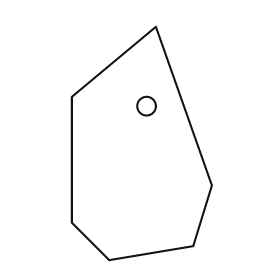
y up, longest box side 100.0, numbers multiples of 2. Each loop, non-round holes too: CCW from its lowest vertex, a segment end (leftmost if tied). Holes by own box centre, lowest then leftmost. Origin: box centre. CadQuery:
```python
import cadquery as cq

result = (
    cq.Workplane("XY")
    .moveTo(-14.0, -50.0)
    .lineTo(22.0, -44.0)
    .lineTo(30.0, -18.0)
    .lineTo(6.0, 50.0)
    .lineTo(-30.0, 20.0)
    .lineTo(-30.0, -34.0)
    .close()
    .moveTo(2.0, 16.0)
    .circle(4.0)
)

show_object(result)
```